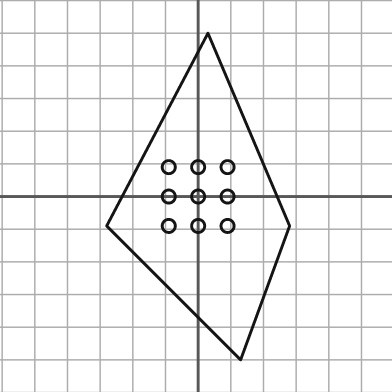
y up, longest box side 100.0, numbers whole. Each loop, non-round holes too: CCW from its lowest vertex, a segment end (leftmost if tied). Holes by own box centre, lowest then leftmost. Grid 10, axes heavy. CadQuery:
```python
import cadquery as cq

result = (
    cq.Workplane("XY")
    .moveTo(13.0, -50.0)
    .lineTo(28.0, -9.0)
    .lineTo(3.0, 50.0)
    .lineTo(-28.0, -9.0)
    .close()
    .moveTo(-9.0, -9.0)
    .circle(2.0)
    .moveTo(0.0, -9.0)
    .circle(2.0)
    .moveTo(9.0, -9.0)
    .circle(2.0)
    .moveTo(-9.0, 0.0)
    .circle(2.0)
    .moveTo(0.0, 0.0)
    .circle(2.0)
    .moveTo(9.0, 0.0)
    .circle(2.0)
    .moveTo(-9.0, 9.0)
    .circle(2.0)
    .moveTo(0.0, 9.0)
    .circle(2.0)
    .moveTo(9.0, 9.0)
    .circle(2.0)
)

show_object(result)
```